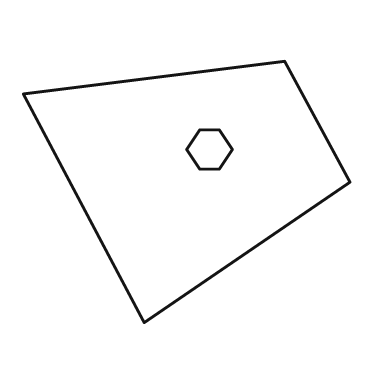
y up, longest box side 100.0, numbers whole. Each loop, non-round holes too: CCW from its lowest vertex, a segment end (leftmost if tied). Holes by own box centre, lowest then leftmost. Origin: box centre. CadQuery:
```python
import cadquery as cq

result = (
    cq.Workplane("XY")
    .moveTo(-13.0, -40.0)
    .lineTo(50.0, 3.0)
    .lineTo(30.0, 40.0)
    .lineTo(-50.0, 30.0)
    .close()
    .moveTo(4.0, 7.0)
    .lineTo(10.0, 7.0)
    .lineTo(14.0, 13.0)
    .lineTo(10.0, 19.0)
    .lineTo(4.0, 19.0)
    .lineTo(0.0, 13.0)
    .close()
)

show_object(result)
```